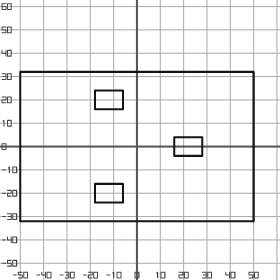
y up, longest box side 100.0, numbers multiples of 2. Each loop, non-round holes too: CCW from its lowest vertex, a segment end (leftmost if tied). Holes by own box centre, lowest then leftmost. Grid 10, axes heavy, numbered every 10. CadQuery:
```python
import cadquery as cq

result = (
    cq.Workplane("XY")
    .moveTo(-50.0, -32.0)
    .lineTo(50.0, -32.0)
    .lineTo(50.0, 32.0)
    .lineTo(-50.0, 32.0)
    .close()
    .moveTo(-18.0, -24.0)
    .lineTo(-6.0, -24.0)
    .lineTo(-6.0, -16.0)
    .lineTo(-18.0, -16.0)
    .close()
    .moveTo(16.0, -4.0)
    .lineTo(28.0, -4.0)
    .lineTo(28.0, 4.0)
    .lineTo(16.0, 4.0)
    .close()
    .moveTo(-18.0, 16.0)
    .lineTo(-6.0, 16.0)
    .lineTo(-6.0, 24.0)
    .lineTo(-18.0, 24.0)
    .close()
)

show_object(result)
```